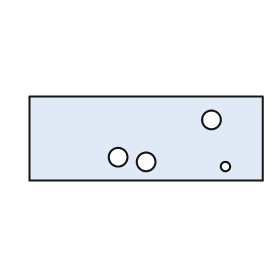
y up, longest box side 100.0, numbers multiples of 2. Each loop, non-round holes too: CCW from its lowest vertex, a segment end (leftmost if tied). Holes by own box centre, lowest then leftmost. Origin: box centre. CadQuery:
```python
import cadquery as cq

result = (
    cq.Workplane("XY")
    .moveTo(-50.0, -18.0)
    .lineTo(50.0, -18.0)
    .lineTo(50.0, 18.0)
    .lineTo(-50.0, 18.0)
    .close()
    .moveTo(34.0, -12.0)
    .circle(2.0)
    .moveTo(0.0, -10.0)
    .circle(4.0)
    .moveTo(-12.0, -8.0)
    .circle(4.0)
    .moveTo(28.0, 8.0)
    .circle(4.0)
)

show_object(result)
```